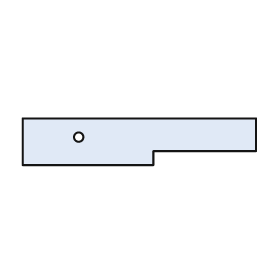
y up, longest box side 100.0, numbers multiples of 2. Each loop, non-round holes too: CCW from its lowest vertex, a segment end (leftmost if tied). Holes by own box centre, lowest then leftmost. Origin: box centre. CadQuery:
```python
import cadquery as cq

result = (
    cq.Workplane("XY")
    .moveTo(-50.0, -10.0)
    .lineTo(6.0, -10.0)
    .lineTo(6.0, -4.0)
    .lineTo(50.0, -4.0)
    .lineTo(50.0, 10.0)
    .lineTo(-50.0, 10.0)
    .close()
    .moveTo(-26.0, 2.0)
    .circle(2.0)
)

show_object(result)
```